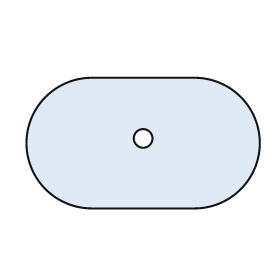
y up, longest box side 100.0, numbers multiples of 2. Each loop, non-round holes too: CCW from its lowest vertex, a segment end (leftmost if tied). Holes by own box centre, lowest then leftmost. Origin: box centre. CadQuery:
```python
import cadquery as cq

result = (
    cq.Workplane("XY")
    .moveTo(-22.0, -28.0)
    .lineTo(22.0, -28.0)
    .threePointArc((50.0, 0.0), (22.0, 28.0))
    .lineTo(-22.0, 28.0)
    .threePointArc((-50.0, 0.0), (-22.0, -28.0))
    .close()
    .moveTo(0.0, 2.0)
    .circle(4.0)
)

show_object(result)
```